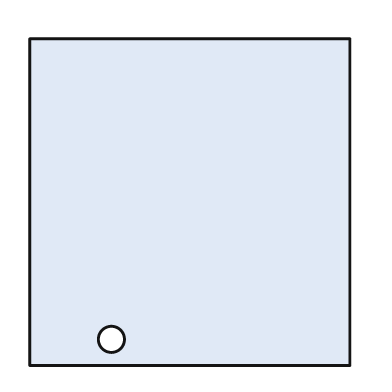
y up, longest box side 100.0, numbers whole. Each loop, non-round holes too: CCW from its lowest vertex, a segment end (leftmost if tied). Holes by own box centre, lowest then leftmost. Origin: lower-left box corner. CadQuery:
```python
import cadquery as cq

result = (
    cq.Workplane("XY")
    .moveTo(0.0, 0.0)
    .lineTo(98.0, 0.0)
    .lineTo(98.0, 100.0)
    .lineTo(0.0, 100.0)
    .close()
    .moveTo(25.0, 8.0)
    .circle(4.0)
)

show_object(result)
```